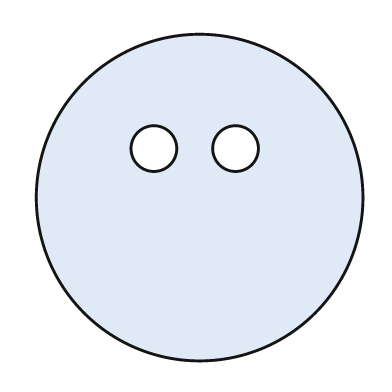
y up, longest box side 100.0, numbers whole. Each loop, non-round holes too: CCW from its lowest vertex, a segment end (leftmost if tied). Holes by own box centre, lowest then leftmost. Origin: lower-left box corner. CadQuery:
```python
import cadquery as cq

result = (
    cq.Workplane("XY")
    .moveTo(50.0, 50.0)
    .circle(50.0)
    .moveTo(36.0, 65.0)
    .circle(7.0)
    .moveTo(61.0, 65.0)
    .circle(7.0)
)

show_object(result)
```